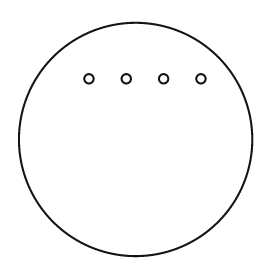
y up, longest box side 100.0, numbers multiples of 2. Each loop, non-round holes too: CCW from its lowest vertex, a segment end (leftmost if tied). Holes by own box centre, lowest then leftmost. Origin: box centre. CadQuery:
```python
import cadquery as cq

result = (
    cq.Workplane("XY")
    .moveTo(0.0, 0.0)
    .circle(50.0)
    .moveTo(-20.0, 26.0)
    .circle(2.0)
    .moveTo(-4.0, 26.0)
    .circle(2.0)
    .moveTo(12.0, 26.0)
    .circle(2.0)
    .moveTo(28.0, 26.0)
    .circle(2.0)
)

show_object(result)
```